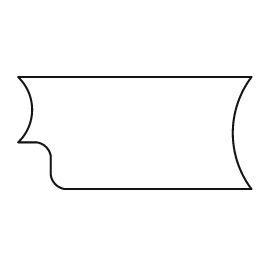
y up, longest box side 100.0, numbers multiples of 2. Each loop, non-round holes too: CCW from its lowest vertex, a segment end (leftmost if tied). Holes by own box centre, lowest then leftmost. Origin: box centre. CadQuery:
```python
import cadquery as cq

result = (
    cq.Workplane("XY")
    .moveTo(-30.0, -24.0)
    .lineTo(50.0, -24.0)
    .threePointArc((42.0, 0.0), (50.0, 24.0))
    .lineTo(-50.0, 24.0)
    .threePointArc((-44.0, 10.0), (-50.0, -4.0))
    .lineTo(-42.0, -4.0)
    .threePointArc((-38.0, -6.0), (-36.0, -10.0))
    .lineTo(-36.0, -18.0)
    .threePointArc((-34.0, -22.0), (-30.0, -24.0))
    .close()
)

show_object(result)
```